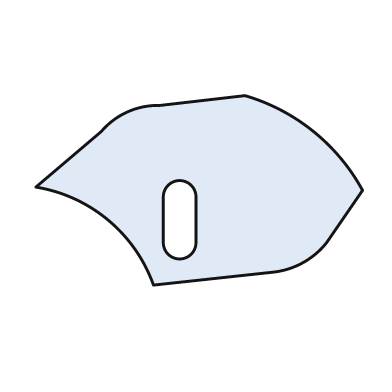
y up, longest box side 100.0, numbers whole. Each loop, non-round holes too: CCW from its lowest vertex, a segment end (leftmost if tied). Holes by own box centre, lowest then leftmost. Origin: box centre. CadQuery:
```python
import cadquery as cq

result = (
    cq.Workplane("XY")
    .moveTo(-14.0, -29.0)
    .lineTo(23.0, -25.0)
    .threePointArc((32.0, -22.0), (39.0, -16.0))
    .lineTo(50.0, 0.0)
    .threePointArc((35.0, 18.0), (14.0, 29.0))
    .lineTo(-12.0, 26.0)
    .threePointArc((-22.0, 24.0), (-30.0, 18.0))
    .lineTo(-50.0, 1.0)
    .threePointArc((-28.0, -9.0), (-14.0, -29.0))
    .close()
    .moveTo(-11.0, -16.0)
    .threePointArc((-6.0, -21.0), (-1.0, -16.0))
    .lineTo(-1.0, -2.0)
    .threePointArc((-6.0, 3.0), (-11.0, -2.0))
    .close()
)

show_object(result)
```